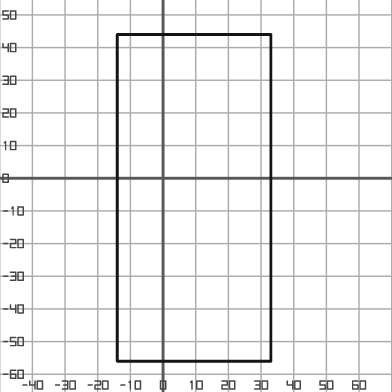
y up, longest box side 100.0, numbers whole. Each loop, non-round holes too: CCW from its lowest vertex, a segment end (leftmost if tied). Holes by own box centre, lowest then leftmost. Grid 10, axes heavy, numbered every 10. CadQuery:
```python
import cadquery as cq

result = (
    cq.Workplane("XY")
    .moveTo(-14.0, -56.0)
    .lineTo(33.0, -56.0)
    .lineTo(33.0, 44.0)
    .lineTo(-14.0, 44.0)
    .close()
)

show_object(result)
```